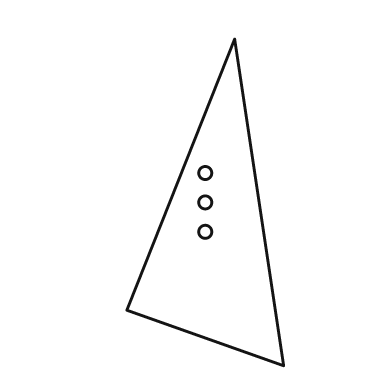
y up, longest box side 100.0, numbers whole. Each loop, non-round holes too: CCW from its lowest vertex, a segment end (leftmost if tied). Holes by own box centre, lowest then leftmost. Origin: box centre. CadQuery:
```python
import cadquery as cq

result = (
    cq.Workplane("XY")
    .moveTo(24.0, -50.0)
    .lineTo(9.0, 50.0)
    .lineTo(-24.0, -33.0)
    .close()
    .moveTo(0.0, -9.0)
    .circle(2.0)
    .moveTo(0.0, 0.0)
    .circle(2.0)
    .moveTo(0.0, 9.0)
    .circle(2.0)
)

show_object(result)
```